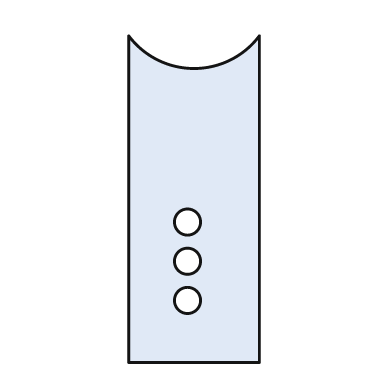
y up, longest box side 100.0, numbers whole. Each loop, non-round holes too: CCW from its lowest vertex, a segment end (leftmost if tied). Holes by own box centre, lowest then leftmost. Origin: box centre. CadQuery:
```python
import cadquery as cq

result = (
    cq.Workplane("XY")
    .moveTo(-20.0, -50.0)
    .lineTo(20.0, -50.0)
    .lineTo(20.0, 50.0)
    .threePointArc((0.0, 40.0), (-20.0, 50.0))
    .close()
    .moveTo(-2.0, -31.0)
    .circle(4.0)
    .moveTo(-2.0, -19.0)
    .circle(4.0)
    .moveTo(-2.0, -7.0)
    .circle(4.0)
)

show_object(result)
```